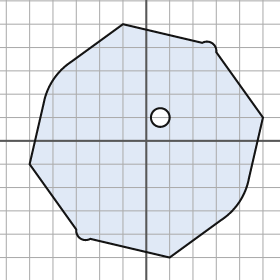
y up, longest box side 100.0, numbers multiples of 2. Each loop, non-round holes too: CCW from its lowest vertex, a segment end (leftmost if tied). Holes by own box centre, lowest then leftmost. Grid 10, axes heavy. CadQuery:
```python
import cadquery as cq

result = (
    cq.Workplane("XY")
    .moveTo(10.0, -50.0)
    .lineTo(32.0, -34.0)
    .threePointArc((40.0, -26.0), (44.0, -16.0))
    .lineTo(50.0, 10.0)
    .lineTo(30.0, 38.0)
    .threePointArc((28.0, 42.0), (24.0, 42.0))
    .lineTo(-10.0, 50.0)
    .lineTo(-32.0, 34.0)
    .threePointArc((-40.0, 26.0), (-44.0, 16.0))
    .lineTo(-50.0, -10.0)
    .lineTo(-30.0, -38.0)
    .threePointArc((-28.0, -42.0), (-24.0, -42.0))
    .close()
    .moveTo(6.0, 10.0)
    .circle(4.0)
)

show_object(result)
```